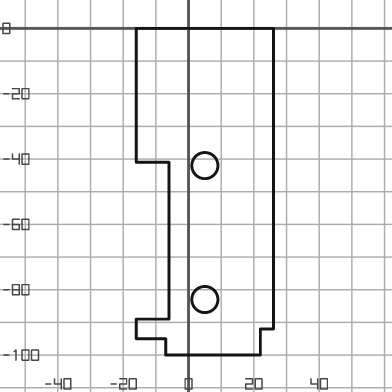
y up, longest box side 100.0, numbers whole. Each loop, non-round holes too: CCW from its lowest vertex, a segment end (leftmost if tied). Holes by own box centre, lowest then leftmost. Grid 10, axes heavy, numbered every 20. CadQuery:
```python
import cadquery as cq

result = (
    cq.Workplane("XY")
    .moveTo(-7.0, -100.0)
    .lineTo(22.0, -100.0)
    .lineTo(22.0, -92.0)
    .lineTo(26.0, -92.0)
    .lineTo(26.0, 0.0)
    .lineTo(-16.0, 0.0)
    .lineTo(-16.0, -41.0)
    .lineTo(-6.0, -41.0)
    .lineTo(-6.0, -89.0)
    .lineTo(-16.0, -89.0)
    .lineTo(-16.0, -95.0)
    .lineTo(-7.0, -95.0)
    .close()
    .moveTo(5.0, -83.0)
    .circle(4.0)
    .moveTo(5.0, -42.0)
    .circle(4.0)
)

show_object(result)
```